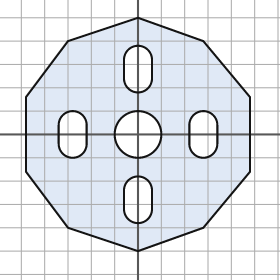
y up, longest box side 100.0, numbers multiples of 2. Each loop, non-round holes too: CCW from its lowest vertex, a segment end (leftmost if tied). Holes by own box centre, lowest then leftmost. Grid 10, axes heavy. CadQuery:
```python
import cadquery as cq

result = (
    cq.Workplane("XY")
    .moveTo(0.0, -50.0)
    .lineTo(28.0, -40.0)
    .lineTo(48.0, -16.0)
    .lineTo(48.0, 16.0)
    .lineTo(28.0, 40.0)
    .lineTo(0.0, 50.0)
    .lineTo(-30.0, 40.0)
    .lineTo(-48.0, 16.0)
    .lineTo(-48.0, -16.0)
    .lineTo(-30.0, -40.0)
    .close()
    .moveTo(-6.0, -32.0)
    .threePointArc((0.0, -38.0), (6.0, -32.0))
    .lineTo(6.0, -24.0)
    .threePointArc((0.0, -18.0), (-6.0, -24.0))
    .close()
    .moveTo(-34.0, -4.0)
    .threePointArc((-28.0, -10.0), (-22.0, -4.0))
    .lineTo(-22.0, 4.0)
    .threePointArc((-28.0, 10.0), (-34.0, 4.0))
    .close()
    .moveTo(0.0, 0.0)
    .circle(10.0)
    .moveTo(22.0, -4.0)
    .threePointArc((28.0, -10.0), (34.0, -4.0))
    .lineTo(34.0, 4.0)
    .threePointArc((28.0, 10.0), (22.0, 4.0))
    .close()
    .moveTo(-6.0, 24.0)
    .threePointArc((0.0, 18.0), (6.0, 24.0))
    .lineTo(6.0, 32.0)
    .threePointArc((0.0, 38.0), (-6.0, 32.0))
    .close()
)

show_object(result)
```